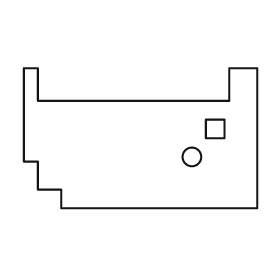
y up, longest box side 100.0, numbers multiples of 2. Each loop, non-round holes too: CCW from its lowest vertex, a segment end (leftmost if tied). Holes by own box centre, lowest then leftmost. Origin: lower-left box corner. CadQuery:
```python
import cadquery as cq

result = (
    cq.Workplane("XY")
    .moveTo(16.0, 0.0)
    .lineTo(100.0, 0.0)
    .lineTo(100.0, 60.0)
    .lineTo(88.0, 60.0)
    .lineTo(88.0, 46.0)
    .lineTo(6.0, 46.0)
    .lineTo(6.0, 60.0)
    .lineTo(0.0, 60.0)
    .lineTo(0.0, 20.0)
    .lineTo(6.0, 20.0)
    .lineTo(6.0, 8.0)
    .lineTo(16.0, 8.0)
    .close()
    .moveTo(72.0, 22.0)
    .circle(4.0)
    .moveTo(78.0, 30.0)
    .lineTo(86.0, 30.0)
    .lineTo(86.0, 38.0)
    .lineTo(78.0, 38.0)
    .close()
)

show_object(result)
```